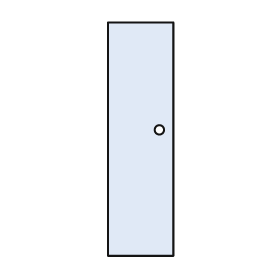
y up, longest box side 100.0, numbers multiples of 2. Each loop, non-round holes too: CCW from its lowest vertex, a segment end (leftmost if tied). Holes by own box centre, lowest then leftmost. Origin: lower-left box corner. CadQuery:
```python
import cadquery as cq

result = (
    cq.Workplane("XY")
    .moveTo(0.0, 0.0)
    .lineTo(28.0, 0.0)
    .lineTo(28.0, 100.0)
    .lineTo(0.0, 100.0)
    .close()
    .moveTo(22.0, 54.0)
    .circle(2.0)
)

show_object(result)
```